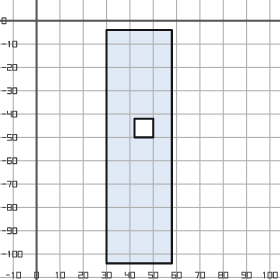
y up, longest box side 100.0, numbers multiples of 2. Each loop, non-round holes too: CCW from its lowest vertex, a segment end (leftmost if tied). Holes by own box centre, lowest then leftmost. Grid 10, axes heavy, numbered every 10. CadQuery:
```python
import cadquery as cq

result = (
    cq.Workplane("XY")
    .moveTo(30.0, -104.0)
    .lineTo(58.0, -104.0)
    .lineTo(58.0, -4.0)
    .lineTo(30.0, -4.0)
    .close()
    .moveTo(42.0, -50.0)
    .lineTo(50.0, -50.0)
    .lineTo(50.0, -42.0)
    .lineTo(42.0, -42.0)
    .close()
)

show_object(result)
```